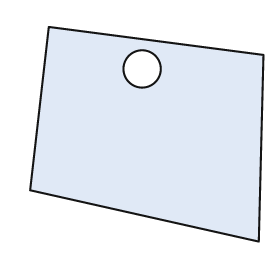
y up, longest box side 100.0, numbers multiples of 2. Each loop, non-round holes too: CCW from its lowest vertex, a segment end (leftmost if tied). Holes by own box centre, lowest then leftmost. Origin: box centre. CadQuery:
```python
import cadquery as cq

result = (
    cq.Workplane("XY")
    .moveTo(48.0, -46.0)
    .lineTo(50.0, 34.0)
    .lineTo(-42.0, 46.0)
    .lineTo(-50.0, -24.0)
    .close()
    .moveTo(-2.0, 28.0)
    .circle(8.0)
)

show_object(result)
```